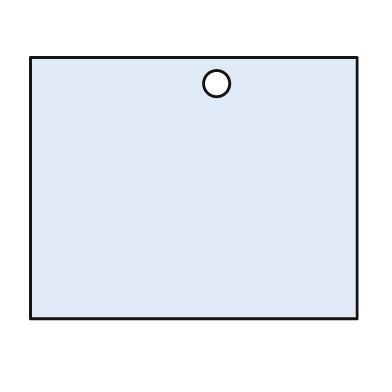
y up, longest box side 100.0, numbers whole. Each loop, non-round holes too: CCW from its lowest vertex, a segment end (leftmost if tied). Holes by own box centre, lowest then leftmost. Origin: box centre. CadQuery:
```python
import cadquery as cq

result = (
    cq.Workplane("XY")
    .moveTo(-50.0, -40.0)
    .lineTo(50.0, -40.0)
    .lineTo(50.0, 40.0)
    .lineTo(-50.0, 40.0)
    .close()
    .moveTo(7.0, 32.0)
    .circle(4.0)
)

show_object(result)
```